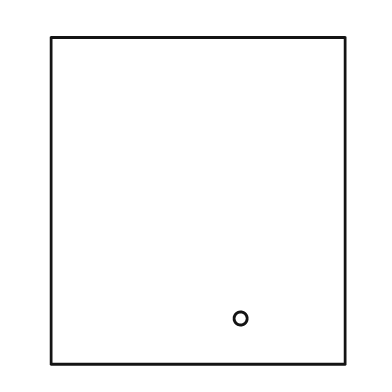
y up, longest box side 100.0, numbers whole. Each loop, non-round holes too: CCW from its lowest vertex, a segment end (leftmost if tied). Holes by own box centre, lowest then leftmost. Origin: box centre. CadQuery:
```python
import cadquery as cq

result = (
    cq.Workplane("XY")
    .moveTo(-45.0, -50.0)
    .lineTo(45.0, -50.0)
    .lineTo(45.0, 50.0)
    .lineTo(-45.0, 50.0)
    .close()
    .moveTo(13.0, -36.0)
    .circle(2.0)
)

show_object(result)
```